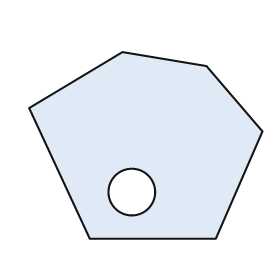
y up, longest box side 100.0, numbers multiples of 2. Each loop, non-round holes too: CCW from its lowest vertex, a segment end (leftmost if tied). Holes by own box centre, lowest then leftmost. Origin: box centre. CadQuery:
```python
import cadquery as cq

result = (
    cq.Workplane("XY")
    .moveTo(-24.0, -40.0)
    .lineTo(30.0, -40.0)
    .lineTo(50.0, 6.0)
    .lineTo(26.0, 34.0)
    .lineTo(-10.0, 40.0)
    .lineTo(-50.0, 16.0)
    .close()
    .moveTo(-6.0, -20.0)
    .circle(10.0)
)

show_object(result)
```